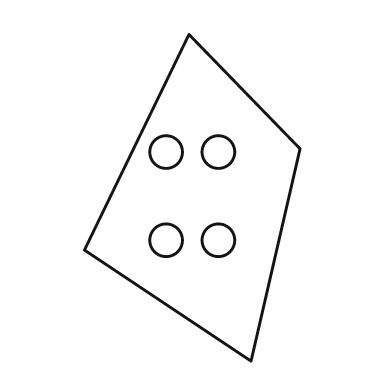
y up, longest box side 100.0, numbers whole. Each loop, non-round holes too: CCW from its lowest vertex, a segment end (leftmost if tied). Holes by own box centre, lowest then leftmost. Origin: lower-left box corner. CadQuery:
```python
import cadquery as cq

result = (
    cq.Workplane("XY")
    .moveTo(51.0, 0.0)
    .lineTo(66.0, 65.0)
    .lineTo(32.0, 100.0)
    .lineTo(0.0, 34.0)
    .close()
    .moveTo(25.0, 37.0)
    .circle(5.0)
    .moveTo(41.0, 37.0)
    .circle(5.0)
    .moveTo(25.0, 64.0)
    .circle(5.0)
    .moveTo(41.0, 64.0)
    .circle(5.0)
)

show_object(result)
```